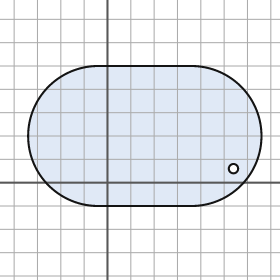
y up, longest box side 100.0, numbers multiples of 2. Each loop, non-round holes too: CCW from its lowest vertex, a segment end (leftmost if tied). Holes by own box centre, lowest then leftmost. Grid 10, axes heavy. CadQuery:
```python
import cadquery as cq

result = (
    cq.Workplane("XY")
    .moveTo(-4.0, -10.0)
    .lineTo(36.0, -10.0)
    .threePointArc((66.0, 20.0), (36.0, 50.0))
    .lineTo(-4.0, 50.0)
    .threePointArc((-34.0, 20.0), (-4.0, -10.0))
    .close()
    .moveTo(54.0, 6.0)
    .circle(2.0)
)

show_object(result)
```